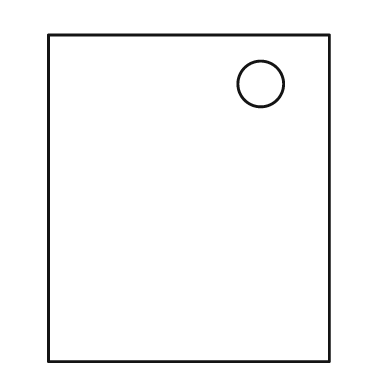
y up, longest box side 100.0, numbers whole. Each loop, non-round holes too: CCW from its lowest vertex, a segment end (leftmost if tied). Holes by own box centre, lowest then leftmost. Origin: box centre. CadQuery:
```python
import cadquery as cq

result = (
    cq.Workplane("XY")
    .moveTo(-43.0, -50.0)
    .lineTo(43.0, -50.0)
    .lineTo(43.0, 50.0)
    .lineTo(-43.0, 50.0)
    .close()
    .moveTo(22.0, 35.0)
    .circle(7.0)
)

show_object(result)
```